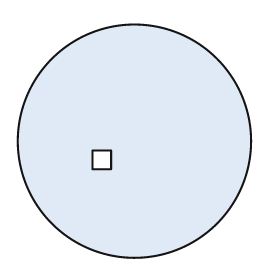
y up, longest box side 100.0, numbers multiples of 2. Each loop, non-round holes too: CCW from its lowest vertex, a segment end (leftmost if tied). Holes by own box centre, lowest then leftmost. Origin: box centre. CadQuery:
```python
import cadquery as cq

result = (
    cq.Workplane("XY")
    .moveTo(0.0, 0.0)
    .circle(50.0)
    .moveTo(-18.0, -12.0)
    .lineTo(-10.0, -12.0)
    .lineTo(-10.0, -4.0)
    .lineTo(-18.0, -4.0)
    .close()
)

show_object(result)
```